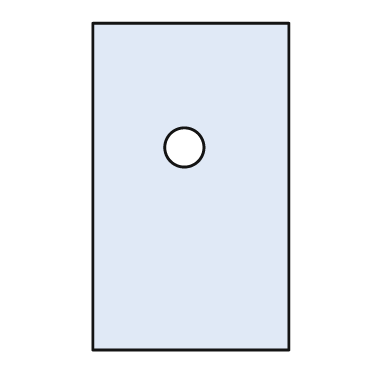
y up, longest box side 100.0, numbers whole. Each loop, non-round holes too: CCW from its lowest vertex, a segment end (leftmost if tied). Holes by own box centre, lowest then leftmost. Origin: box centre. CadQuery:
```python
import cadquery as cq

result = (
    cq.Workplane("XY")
    .moveTo(-30.0, -50.0)
    .lineTo(30.0, -50.0)
    .lineTo(30.0, 50.0)
    .lineTo(-30.0, 50.0)
    .close()
    .moveTo(-2.0, 12.0)
    .circle(6.0)
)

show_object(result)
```